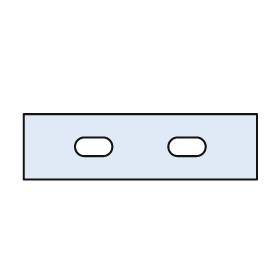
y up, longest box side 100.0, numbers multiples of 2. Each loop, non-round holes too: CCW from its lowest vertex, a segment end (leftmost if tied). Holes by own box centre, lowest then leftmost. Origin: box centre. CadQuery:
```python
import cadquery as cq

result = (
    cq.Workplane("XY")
    .moveTo(-50.0, -14.0)
    .lineTo(50.0, -14.0)
    .lineTo(50.0, 14.0)
    .lineTo(-50.0, 14.0)
    .close()
    .moveTo(-24.0, -4.0)
    .lineTo(-16.0, -4.0)
    .threePointArc((-12.0, 0.0), (-16.0, 4.0))
    .lineTo(-24.0, 4.0)
    .threePointArc((-28.0, 0.0), (-24.0, -4.0))
    .close()
    .moveTo(16.0, -4.0)
    .lineTo(24.0, -4.0)
    .threePointArc((28.0, 0.0), (24.0, 4.0))
    .lineTo(16.0, 4.0)
    .threePointArc((12.0, 0.0), (16.0, -4.0))
    .close()
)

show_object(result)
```